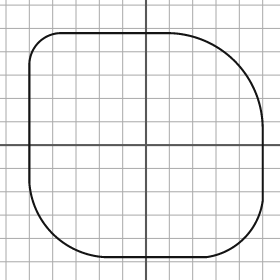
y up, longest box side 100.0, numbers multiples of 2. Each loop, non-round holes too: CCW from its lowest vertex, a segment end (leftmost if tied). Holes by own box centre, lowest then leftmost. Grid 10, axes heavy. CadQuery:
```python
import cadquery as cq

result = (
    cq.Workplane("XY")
    .moveTo(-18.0, -48.0)
    .lineTo(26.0, -48.0)
    .threePointArc((42.0, -40.0), (50.0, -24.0))
    .lineTo(50.0, 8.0)
    .threePointArc((38.0, 36.0), (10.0, 48.0))
    .lineTo(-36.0, 48.0)
    .threePointArc((-46.0, 44.0), (-50.0, 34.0))
    .lineTo(-50.0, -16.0)
    .threePointArc((-40.0, -38.0), (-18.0, -48.0))
    .close()
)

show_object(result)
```